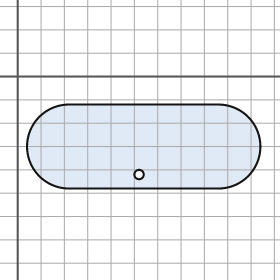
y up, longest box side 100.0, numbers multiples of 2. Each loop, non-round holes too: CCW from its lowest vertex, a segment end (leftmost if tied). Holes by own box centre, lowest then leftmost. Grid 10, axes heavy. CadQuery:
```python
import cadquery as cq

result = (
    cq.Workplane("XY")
    .moveTo(22.0, -48.0)
    .lineTo(86.0, -48.0)
    .threePointArc((104.0, -30.0), (86.0, -12.0))
    .lineTo(22.0, -12.0)
    .threePointArc((4.0, -30.0), (22.0, -48.0))
    .close()
    .moveTo(52.0, -42.0)
    .circle(2.0)
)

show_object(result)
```